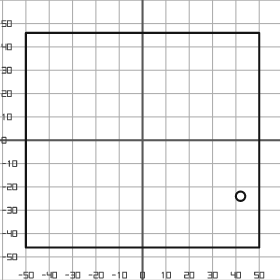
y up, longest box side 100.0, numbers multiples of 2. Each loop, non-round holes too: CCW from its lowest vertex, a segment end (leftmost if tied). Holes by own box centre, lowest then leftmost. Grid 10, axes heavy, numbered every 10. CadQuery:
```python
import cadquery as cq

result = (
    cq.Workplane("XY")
    .moveTo(-50.0, -46.0)
    .lineTo(50.0, -46.0)
    .lineTo(50.0, 46.0)
    .lineTo(-50.0, 46.0)
    .close()
    .moveTo(42.0, -24.0)
    .circle(2.0)
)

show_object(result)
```